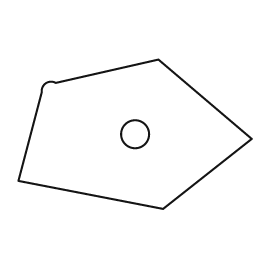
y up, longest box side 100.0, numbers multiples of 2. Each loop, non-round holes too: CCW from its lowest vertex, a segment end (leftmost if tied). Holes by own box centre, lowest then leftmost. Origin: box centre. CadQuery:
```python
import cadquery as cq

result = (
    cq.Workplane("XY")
    .moveTo(12.0, -32.0)
    .lineTo(50.0, -2.0)
    .lineTo(10.0, 32.0)
    .lineTo(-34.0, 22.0)
    .threePointArc((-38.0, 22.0), (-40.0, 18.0))
    .lineTo(-50.0, -20.0)
    .close()
    .moveTo(0.0, 0.0)
    .circle(6.0)
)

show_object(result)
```